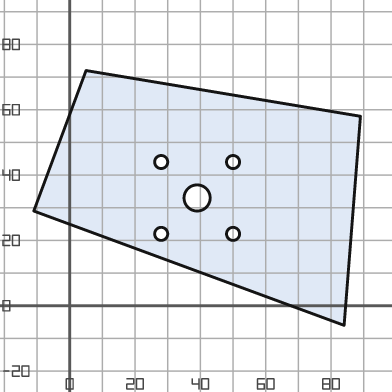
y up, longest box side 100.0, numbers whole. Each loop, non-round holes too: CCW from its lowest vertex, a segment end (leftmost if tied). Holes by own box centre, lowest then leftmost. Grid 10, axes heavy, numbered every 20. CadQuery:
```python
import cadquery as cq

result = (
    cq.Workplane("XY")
    .moveTo(84.0, -6.0)
    .lineTo(89.0, 58.0)
    .lineTo(5.0, 72.0)
    .lineTo(-11.0, 29.0)
    .close()
    .moveTo(28.0, 22.0)
    .circle(2.0)
    .moveTo(50.0, 22.0)
    .circle(2.0)
    .moveTo(39.0, 33.0)
    .circle(4.0)
    .moveTo(28.0, 44.0)
    .circle(2.0)
    .moveTo(50.0, 44.0)
    .circle(2.0)
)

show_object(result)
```